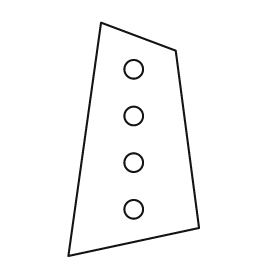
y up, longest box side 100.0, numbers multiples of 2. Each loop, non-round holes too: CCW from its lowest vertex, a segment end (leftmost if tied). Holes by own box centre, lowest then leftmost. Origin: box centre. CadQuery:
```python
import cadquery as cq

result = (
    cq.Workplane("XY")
    .moveTo(-28.0, -50.0)
    .lineTo(28.0, -38.0)
    .lineTo(18.0, 38.0)
    .lineTo(-14.0, 50.0)
    .close()
    .moveTo(0.0, -30.0)
    .circle(4.0)
    .moveTo(0.0, -10.0)
    .circle(4.0)
    .moveTo(0.0, 10.0)
    .circle(4.0)
    .moveTo(0.0, 30.0)
    .circle(4.0)
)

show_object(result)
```